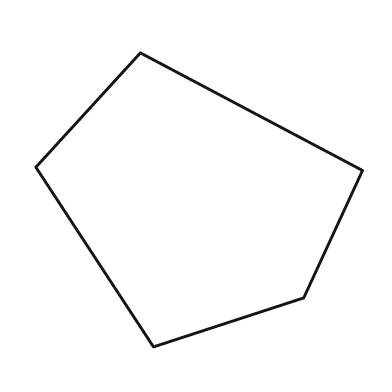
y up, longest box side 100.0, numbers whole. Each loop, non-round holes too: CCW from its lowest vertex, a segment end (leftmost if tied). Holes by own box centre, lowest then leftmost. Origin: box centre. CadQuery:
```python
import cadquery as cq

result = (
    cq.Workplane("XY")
    .moveTo(-14.0, -45.0)
    .lineTo(32.0, -30.0)
    .lineTo(50.0, 9.0)
    .lineTo(-18.0, 45.0)
    .lineTo(-50.0, 10.0)
    .close()
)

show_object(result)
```